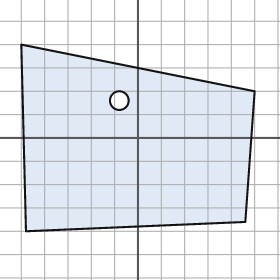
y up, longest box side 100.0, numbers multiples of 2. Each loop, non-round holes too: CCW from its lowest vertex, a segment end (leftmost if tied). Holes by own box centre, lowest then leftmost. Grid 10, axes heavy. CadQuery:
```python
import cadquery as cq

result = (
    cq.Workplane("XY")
    .moveTo(-48.0, -40.0)
    .lineTo(46.0, -36.0)
    .lineTo(50.0, 20.0)
    .lineTo(-50.0, 40.0)
    .close()
    .moveTo(-8.0, 16.0)
    .circle(4.0)
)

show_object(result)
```